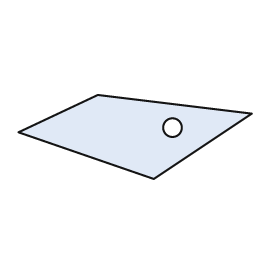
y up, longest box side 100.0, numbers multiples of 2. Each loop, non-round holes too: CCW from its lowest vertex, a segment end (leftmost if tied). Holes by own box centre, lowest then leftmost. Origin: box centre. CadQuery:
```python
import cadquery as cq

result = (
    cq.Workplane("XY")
    .moveTo(8.0, -18.0)
    .lineTo(50.0, 10.0)
    .lineTo(-16.0, 18.0)
    .lineTo(-50.0, 2.0)
    .close()
    .moveTo(16.0, 4.0)
    .circle(4.0)
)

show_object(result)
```